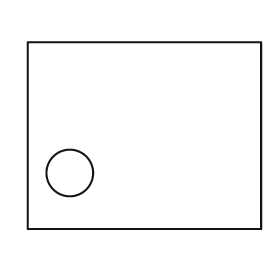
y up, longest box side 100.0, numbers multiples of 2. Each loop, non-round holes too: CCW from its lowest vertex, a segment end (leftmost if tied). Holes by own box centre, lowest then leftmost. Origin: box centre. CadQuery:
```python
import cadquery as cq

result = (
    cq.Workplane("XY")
    .moveTo(-50.0, -40.0)
    .lineTo(50.0, -40.0)
    .lineTo(50.0, 40.0)
    .lineTo(-50.0, 40.0)
    .close()
    .moveTo(-32.0, -16.0)
    .circle(10.0)
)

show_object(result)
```